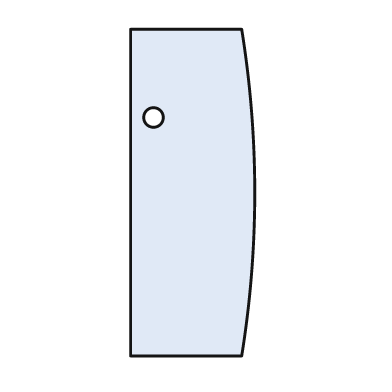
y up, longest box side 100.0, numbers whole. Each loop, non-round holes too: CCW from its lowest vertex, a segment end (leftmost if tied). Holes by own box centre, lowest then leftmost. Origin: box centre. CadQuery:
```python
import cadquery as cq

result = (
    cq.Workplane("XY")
    .moveTo(-19.0, -50.0)
    .lineTo(15.0, -50.0)
    .threePointArc((19.0, 0.0), (15.0, 50.0))
    .lineTo(-19.0, 50.0)
    .close()
    .moveTo(-12.0, 23.0)
    .circle(3.0)
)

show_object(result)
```